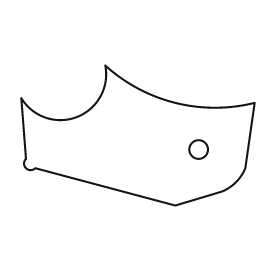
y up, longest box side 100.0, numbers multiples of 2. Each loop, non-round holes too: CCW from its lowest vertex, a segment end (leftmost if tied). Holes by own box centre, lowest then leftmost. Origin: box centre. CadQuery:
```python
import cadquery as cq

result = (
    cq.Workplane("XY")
    .moveTo(16.0, -30.0)
    .lineTo(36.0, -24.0)
    .threePointArc((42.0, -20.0), (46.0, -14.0))
    .lineTo(50.0, 14.0)
    .threePointArc((16.0, 14.0), (-14.0, 30.0))
    .threePointArc((-26.0, 8.0), (-50.0, 16.0))
    .lineTo(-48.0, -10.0)
    .threePointArc((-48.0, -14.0), (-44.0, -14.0))
    .close()
    .moveTo(26.0, -6.0)
    .circle(4.0)
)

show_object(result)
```